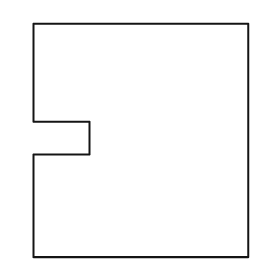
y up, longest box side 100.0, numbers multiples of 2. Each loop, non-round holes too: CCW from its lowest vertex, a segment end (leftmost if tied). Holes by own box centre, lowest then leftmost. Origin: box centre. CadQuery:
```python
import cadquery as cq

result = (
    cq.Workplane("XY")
    .moveTo(-46.0, -50.0)
    .lineTo(46.0, -50.0)
    .lineTo(46.0, 50.0)
    .lineTo(-46.0, 50.0)
    .lineTo(-46.0, 8.0)
    .lineTo(-22.0, 8.0)
    .lineTo(-22.0, -6.0)
    .lineTo(-46.0, -6.0)
    .close()
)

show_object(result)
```